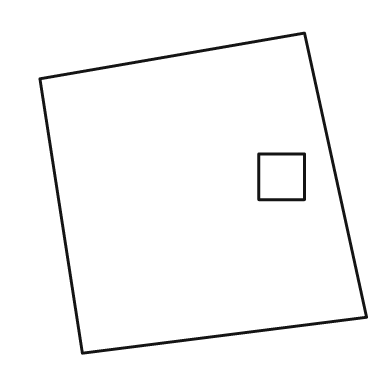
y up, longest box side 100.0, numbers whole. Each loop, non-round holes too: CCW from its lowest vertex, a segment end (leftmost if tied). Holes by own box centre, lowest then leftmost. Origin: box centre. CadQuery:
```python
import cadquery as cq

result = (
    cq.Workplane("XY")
    .moveTo(-37.0, -49.0)
    .lineTo(50.0, -38.0)
    .lineTo(31.0, 49.0)
    .lineTo(-50.0, 35.0)
    .close()
    .moveTo(17.0, -2.0)
    .lineTo(31.0, -2.0)
    .lineTo(31.0, 12.0)
    .lineTo(17.0, 12.0)
    .close()
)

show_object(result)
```